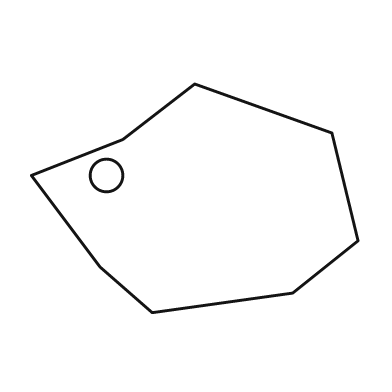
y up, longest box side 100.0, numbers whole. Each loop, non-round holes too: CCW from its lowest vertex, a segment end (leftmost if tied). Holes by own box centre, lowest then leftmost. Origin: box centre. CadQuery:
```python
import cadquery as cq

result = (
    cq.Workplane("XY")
    .moveTo(-13.0, -35.0)
    .lineTo(30.0, -29.0)
    .lineTo(50.0, -13.0)
    .lineTo(42.0, 20.0)
    .lineTo(0.0, 35.0)
    .lineTo(-22.0, 18.0)
    .lineTo(-50.0, 7.0)
    .lineTo(-29.0, -21.0)
    .close()
    .moveTo(-27.0, 7.0)
    .circle(5.0)
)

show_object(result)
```